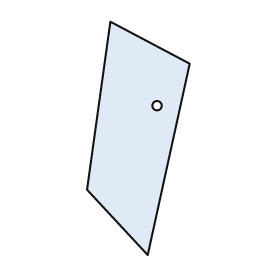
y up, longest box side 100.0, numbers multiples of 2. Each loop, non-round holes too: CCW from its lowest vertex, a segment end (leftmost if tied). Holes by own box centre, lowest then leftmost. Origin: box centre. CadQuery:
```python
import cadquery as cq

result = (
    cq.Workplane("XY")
    .moveTo(4.0, -50.0)
    .lineTo(22.0, 32.0)
    .lineTo(-12.0, 50.0)
    .lineTo(-22.0, -22.0)
    .close()
    .moveTo(8.0, 14.0)
    .circle(2.0)
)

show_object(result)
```